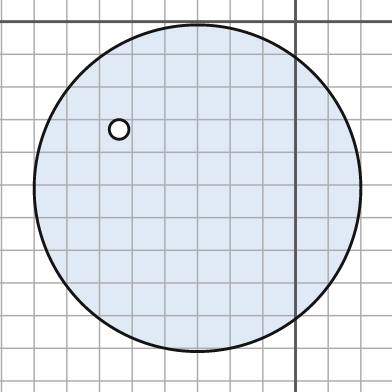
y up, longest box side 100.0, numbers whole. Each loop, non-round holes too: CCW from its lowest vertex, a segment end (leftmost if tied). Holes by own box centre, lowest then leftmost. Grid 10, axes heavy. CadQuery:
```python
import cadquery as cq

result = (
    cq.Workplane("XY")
    .moveTo(-30.0, -51.0)
    .circle(50.0)
    .moveTo(-54.0, -33.0)
    .circle(3.0)
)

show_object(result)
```